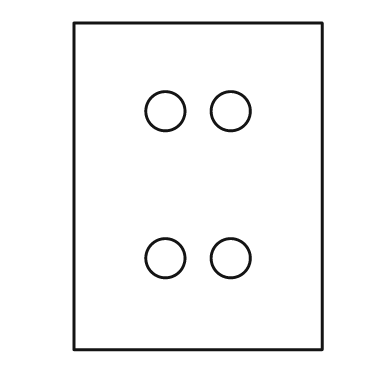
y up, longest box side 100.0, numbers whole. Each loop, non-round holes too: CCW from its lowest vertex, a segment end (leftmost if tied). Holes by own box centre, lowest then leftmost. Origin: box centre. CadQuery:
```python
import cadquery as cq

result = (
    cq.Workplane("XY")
    .moveTo(-38.0, -50.0)
    .lineTo(38.0, -50.0)
    .lineTo(38.0, 50.0)
    .lineTo(-38.0, 50.0)
    .close()
    .moveTo(-10.0, -22.0)
    .circle(6.0)
    .moveTo(10.0, -22.0)
    .circle(6.0)
    .moveTo(-10.0, 23.0)
    .circle(6.0)
    .moveTo(10.0, 23.0)
    .circle(6.0)
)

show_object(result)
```